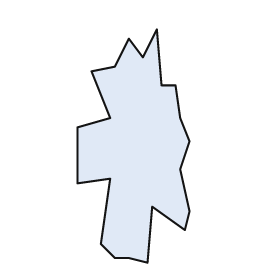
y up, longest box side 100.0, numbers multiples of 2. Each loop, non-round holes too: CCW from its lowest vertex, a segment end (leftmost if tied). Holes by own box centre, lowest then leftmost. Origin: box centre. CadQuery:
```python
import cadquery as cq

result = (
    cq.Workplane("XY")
    .moveTo(6.0, -50.0)
    .lineTo(8.0, -26.0)
    .lineTo(22.0, -36.0)
    .lineTo(24.0, -28.0)
    .lineTo(20.0, -10.0)
    .lineTo(24.0, 2.0)
    .lineTo(20.0, 12.0)
    .lineTo(18.0, 26.0)
    .lineTo(12.0, 26.0)
    .lineTo(10.0, 50.0)
    .lineTo(4.0, 38.0)
    .lineTo(-2.0, 46.0)
    .lineTo(-8.0, 34.0)
    .lineTo(-18.0, 32.0)
    .lineTo(-10.0, 12.0)
    .lineTo(-24.0, 8.0)
    .lineTo(-24.0, -16.0)
    .lineTo(-10.0, -14.0)
    .lineTo(-14.0, -42.0)
    .lineTo(-8.0, -48.0)
    .lineTo(-2.0, -48.0)
    .close()
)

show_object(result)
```